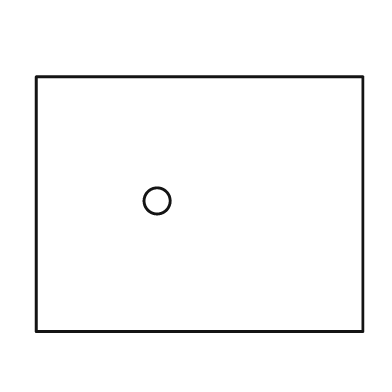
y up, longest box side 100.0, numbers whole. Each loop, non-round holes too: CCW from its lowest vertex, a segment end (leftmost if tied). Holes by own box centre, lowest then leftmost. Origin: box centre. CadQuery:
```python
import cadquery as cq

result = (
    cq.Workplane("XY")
    .moveTo(-50.0, -39.0)
    .lineTo(50.0, -39.0)
    .lineTo(50.0, 39.0)
    .lineTo(-50.0, 39.0)
    .close()
    .moveTo(-13.0, 1.0)
    .circle(4.0)
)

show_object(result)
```